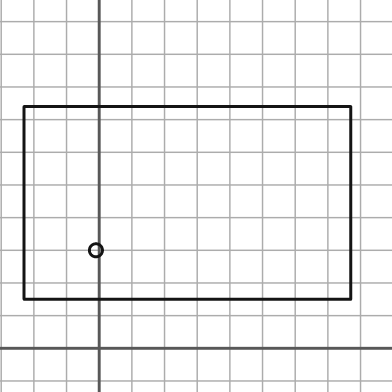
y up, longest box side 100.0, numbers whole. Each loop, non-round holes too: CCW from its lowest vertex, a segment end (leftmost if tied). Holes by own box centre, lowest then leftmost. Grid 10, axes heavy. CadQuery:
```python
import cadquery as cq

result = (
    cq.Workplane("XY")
    .moveTo(-23.0, 15.0)
    .lineTo(77.0, 15.0)
    .lineTo(77.0, 74.0)
    .lineTo(-23.0, 74.0)
    .close()
    .moveTo(-1.0, 30.0)
    .circle(2.0)
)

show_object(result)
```